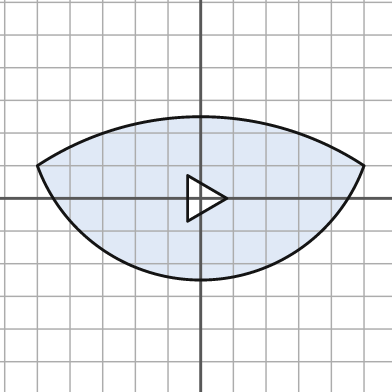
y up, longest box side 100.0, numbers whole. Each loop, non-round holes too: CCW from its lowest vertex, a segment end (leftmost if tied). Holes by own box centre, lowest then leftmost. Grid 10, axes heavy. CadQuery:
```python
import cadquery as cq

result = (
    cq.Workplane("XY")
    .moveTo(-50.0, 10.0)
    .threePointArc((0.0, -25.0), (50.0, 10.0))
    .threePointArc((0.0, 25.0), (-50.0, 10.0))
    .close()
    .moveTo(-4.0, -7.0)
    .lineTo(8.0, 0.0)
    .lineTo(-4.0, 7.0)
    .close()
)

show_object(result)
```